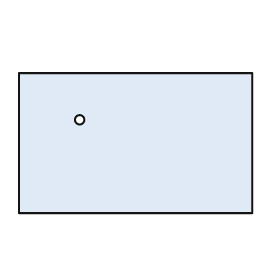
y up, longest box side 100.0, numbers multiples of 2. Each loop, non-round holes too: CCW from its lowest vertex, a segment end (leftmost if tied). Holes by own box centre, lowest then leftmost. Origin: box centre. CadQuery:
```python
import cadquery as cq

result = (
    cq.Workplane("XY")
    .moveTo(-50.0, -30.0)
    .lineTo(50.0, -30.0)
    .lineTo(50.0, 30.0)
    .lineTo(-50.0, 30.0)
    .close()
    .moveTo(-24.0, 10.0)
    .circle(2.0)
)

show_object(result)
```